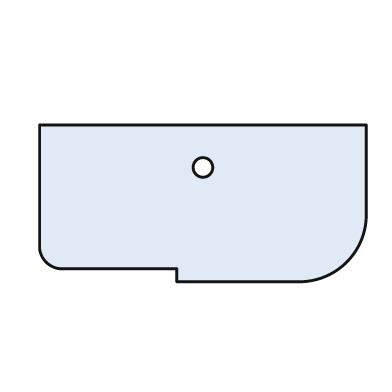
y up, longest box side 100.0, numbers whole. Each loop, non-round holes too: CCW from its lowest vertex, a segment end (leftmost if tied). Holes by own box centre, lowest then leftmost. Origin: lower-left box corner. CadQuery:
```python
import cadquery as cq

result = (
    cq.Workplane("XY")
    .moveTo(42.0, 0.0)
    .lineTo(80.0, 0.0)
    .threePointArc((94.0, 6.0), (100.0, 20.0))
    .lineTo(100.0, 48.0)
    .lineTo(0.0, 48.0)
    .lineTo(0.0, 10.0)
    .threePointArc((2.0, 6.0), (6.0, 4.0))
    .lineTo(42.0, 4.0)
    .close()
    .moveTo(50.0, 35.0)
    .circle(3.0)
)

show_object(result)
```